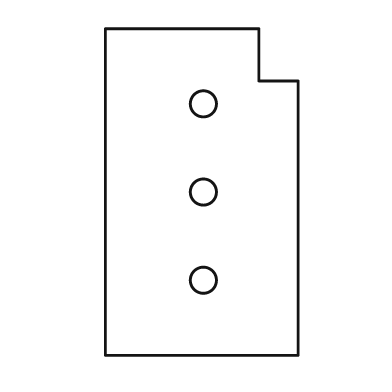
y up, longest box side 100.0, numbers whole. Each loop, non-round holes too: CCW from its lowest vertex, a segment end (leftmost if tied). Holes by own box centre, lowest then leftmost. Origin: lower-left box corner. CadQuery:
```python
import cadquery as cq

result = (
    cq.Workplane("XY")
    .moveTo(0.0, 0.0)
    .lineTo(59.0, 0.0)
    .lineTo(59.0, 84.0)
    .lineTo(47.0, 84.0)
    .lineTo(47.0, 100.0)
    .lineTo(0.0, 100.0)
    .close()
    .moveTo(30.0, 23.0)
    .circle(4.0)
    .moveTo(30.0, 50.0)
    .circle(4.0)
    .moveTo(30.0, 77.0)
    .circle(4.0)
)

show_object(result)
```